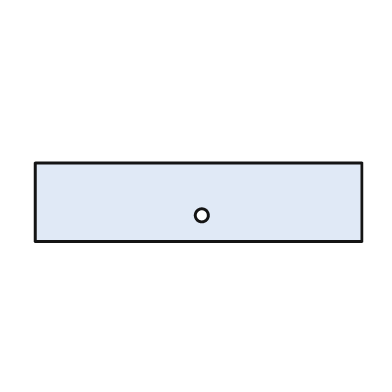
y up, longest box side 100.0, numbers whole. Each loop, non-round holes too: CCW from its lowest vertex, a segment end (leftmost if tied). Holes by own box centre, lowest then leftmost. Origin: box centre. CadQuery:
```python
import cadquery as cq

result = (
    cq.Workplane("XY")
    .moveTo(-50.0, -12.0)
    .lineTo(50.0, -12.0)
    .lineTo(50.0, 12.0)
    .lineTo(-50.0, 12.0)
    .close()
    .moveTo(1.0, -4.0)
    .circle(2.0)
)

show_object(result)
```